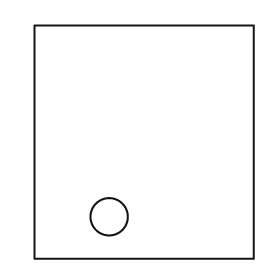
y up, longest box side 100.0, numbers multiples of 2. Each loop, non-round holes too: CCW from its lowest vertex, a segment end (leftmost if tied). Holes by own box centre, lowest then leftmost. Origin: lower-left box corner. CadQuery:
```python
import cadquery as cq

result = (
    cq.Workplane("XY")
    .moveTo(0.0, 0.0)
    .lineTo(94.0, 0.0)
    .lineTo(94.0, 100.0)
    .lineTo(0.0, 100.0)
    .close()
    .moveTo(32.0, 18.0)
    .circle(8.0)
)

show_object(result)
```